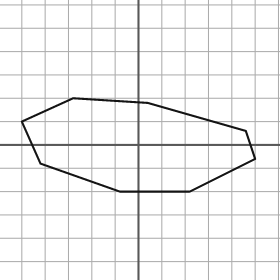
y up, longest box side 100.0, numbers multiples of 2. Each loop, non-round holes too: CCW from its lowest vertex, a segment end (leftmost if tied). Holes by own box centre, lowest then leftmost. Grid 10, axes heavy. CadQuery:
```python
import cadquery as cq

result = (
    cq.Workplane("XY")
    .moveTo(-8.0, -20.0)
    .lineTo(22.0, -20.0)
    .lineTo(50.0, -6.0)
    .lineTo(46.0, 6.0)
    .lineTo(4.0, 18.0)
    .lineTo(-28.0, 20.0)
    .lineTo(-50.0, 10.0)
    .lineTo(-42.0, -8.0)
    .close()
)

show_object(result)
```